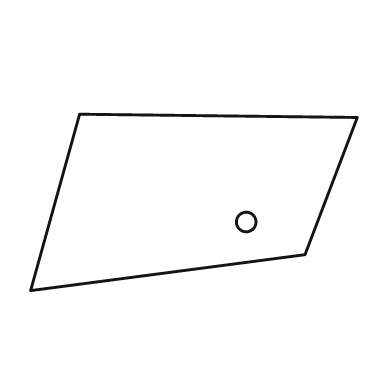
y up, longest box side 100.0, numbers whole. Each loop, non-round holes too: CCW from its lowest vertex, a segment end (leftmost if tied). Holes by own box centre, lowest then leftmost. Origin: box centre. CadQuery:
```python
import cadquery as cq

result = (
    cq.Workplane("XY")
    .moveTo(-50.0, -27.0)
    .lineTo(34.0, -16.0)
    .lineTo(50.0, 26.0)
    .lineTo(-35.0, 27.0)
    .close()
    .moveTo(16.0, -6.0)
    .circle(3.0)
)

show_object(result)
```